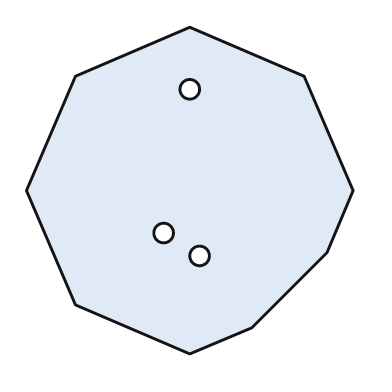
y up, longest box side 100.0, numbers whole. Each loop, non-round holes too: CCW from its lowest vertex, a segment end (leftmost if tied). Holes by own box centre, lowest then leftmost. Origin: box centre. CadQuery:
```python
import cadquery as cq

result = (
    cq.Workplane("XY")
    .moveTo(0.0, -50.0)
    .lineTo(19.0, -42.0)
    .lineTo(42.0, -19.0)
    .lineTo(50.0, 0.0)
    .lineTo(35.0, 35.0)
    .lineTo(0.0, 50.0)
    .lineTo(-35.0, 35.0)
    .lineTo(-50.0, 0.0)
    .lineTo(-35.0, -35.0)
    .close()
    .moveTo(3.0, -20.0)
    .circle(3.0)
    .moveTo(-8.0, -13.0)
    .circle(3.0)
    .moveTo(0.0, 31.0)
    .circle(3.0)
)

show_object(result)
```